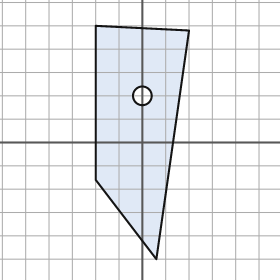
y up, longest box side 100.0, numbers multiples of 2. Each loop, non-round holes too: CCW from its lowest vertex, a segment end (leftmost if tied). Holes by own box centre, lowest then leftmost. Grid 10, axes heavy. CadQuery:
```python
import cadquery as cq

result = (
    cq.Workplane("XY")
    .moveTo(6.0, -50.0)
    .lineTo(20.0, 48.0)
    .lineTo(-20.0, 50.0)
    .lineTo(-20.0, -16.0)
    .close()
    .moveTo(0.0, 20.0)
    .circle(4.0)
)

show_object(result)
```